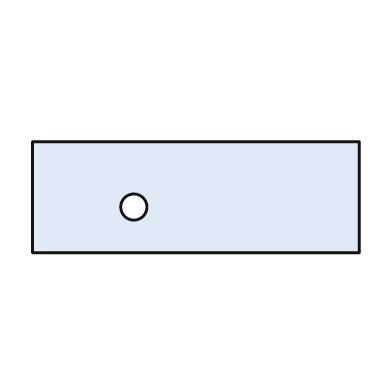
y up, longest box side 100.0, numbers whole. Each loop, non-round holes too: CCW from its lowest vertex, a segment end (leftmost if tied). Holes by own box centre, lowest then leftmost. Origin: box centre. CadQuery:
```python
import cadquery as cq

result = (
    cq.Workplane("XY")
    .moveTo(-50.0, -17.0)
    .lineTo(50.0, -17.0)
    .lineTo(50.0, 17.0)
    .lineTo(-50.0, 17.0)
    .close()
    .moveTo(-19.0, -3.0)
    .circle(4.0)
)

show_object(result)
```